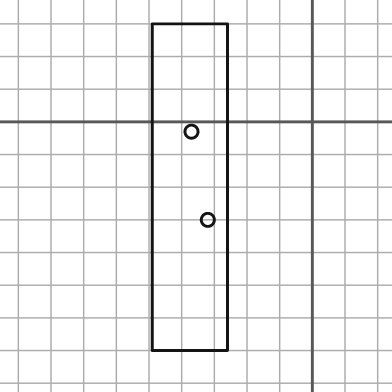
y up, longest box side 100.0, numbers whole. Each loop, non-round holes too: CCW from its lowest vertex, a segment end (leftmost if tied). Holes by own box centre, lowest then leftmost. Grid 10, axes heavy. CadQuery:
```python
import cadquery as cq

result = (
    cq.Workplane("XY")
    .moveTo(-49.0, -70.0)
    .lineTo(-26.0, -70.0)
    .lineTo(-26.0, 30.0)
    .lineTo(-49.0, 30.0)
    .close()
    .moveTo(-32.0, -30.0)
    .circle(2.0)
    .moveTo(-37.0, -3.0)
    .circle(2.0)
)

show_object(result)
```